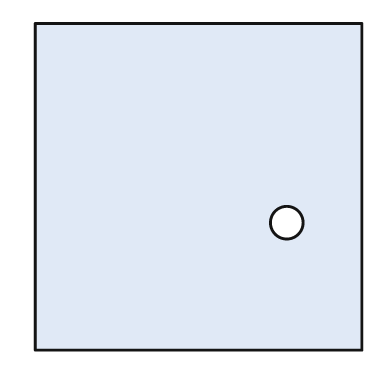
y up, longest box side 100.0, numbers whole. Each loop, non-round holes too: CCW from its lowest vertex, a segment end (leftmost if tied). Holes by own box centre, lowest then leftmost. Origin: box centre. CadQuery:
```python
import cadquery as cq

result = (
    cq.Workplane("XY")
    .moveTo(-50.0, -50.0)
    .lineTo(50.0, -50.0)
    .lineTo(50.0, 50.0)
    .lineTo(-50.0, 50.0)
    .close()
    .moveTo(27.0, -11.0)
    .circle(5.0)
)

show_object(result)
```